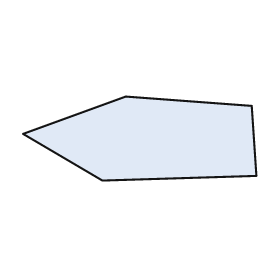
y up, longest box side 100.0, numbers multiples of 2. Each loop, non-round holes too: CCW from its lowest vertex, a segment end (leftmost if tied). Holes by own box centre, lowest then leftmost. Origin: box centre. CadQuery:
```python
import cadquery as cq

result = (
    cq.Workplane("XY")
    .moveTo(-16.0, -18.0)
    .lineTo(50.0, -16.0)
    .lineTo(48.0, 14.0)
    .lineTo(-6.0, 18.0)
    .lineTo(-50.0, 2.0)
    .close()
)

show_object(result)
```